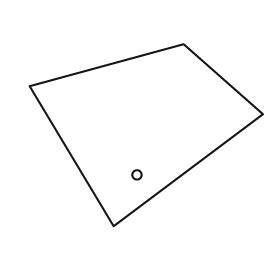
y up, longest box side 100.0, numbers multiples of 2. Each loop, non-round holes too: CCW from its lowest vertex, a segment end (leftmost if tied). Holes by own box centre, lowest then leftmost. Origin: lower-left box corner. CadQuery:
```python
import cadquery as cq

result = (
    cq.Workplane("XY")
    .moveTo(36.0, 0.0)
    .lineTo(100.0, 48.0)
    .lineTo(66.0, 78.0)
    .lineTo(0.0, 60.0)
    .close()
    .moveTo(46.0, 22.0)
    .circle(2.0)
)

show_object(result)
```